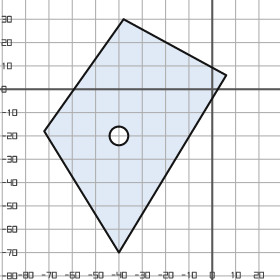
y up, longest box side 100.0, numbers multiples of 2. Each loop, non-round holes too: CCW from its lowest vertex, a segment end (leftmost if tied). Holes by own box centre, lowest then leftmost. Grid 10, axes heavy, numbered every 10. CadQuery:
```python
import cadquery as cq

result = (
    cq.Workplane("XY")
    .moveTo(-40.0, -70.0)
    .lineTo(6.0, 6.0)
    .lineTo(-38.0, 30.0)
    .lineTo(-72.0, -18.0)
    .close()
    .moveTo(-40.0, -20.0)
    .circle(4.0)
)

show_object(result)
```